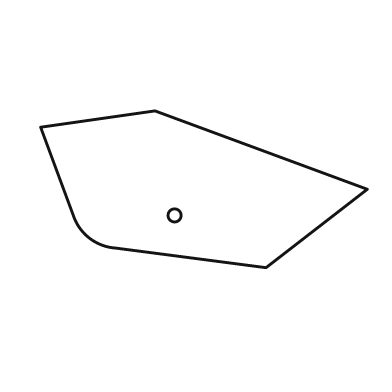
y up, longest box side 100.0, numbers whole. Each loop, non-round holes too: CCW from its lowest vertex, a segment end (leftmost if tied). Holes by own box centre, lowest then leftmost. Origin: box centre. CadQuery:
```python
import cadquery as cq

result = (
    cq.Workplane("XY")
    .moveTo(19.0, -24.0)
    .lineTo(50.0, 0.0)
    .lineTo(-15.0, 24.0)
    .lineTo(-50.0, 19.0)
    .lineTo(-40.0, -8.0)
    .threePointArc((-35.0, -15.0), (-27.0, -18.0))
    .close()
    .moveTo(-9.0, -8.0)
    .circle(2.0)
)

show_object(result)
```